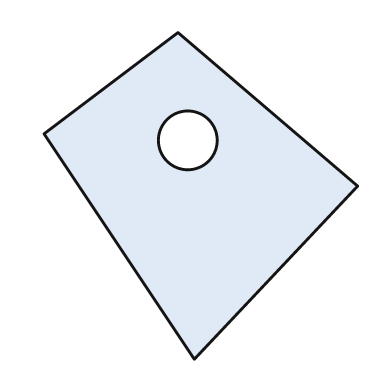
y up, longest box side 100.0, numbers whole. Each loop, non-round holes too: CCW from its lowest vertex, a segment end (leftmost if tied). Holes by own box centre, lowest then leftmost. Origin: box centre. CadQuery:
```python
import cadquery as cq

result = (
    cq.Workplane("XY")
    .moveTo(-2.0, -50.0)
    .lineTo(48.0, 3.0)
    .lineTo(-7.0, 50.0)
    .lineTo(-48.0, 19.0)
    .close()
    .moveTo(-4.0, 17.0)
    .circle(9.0)
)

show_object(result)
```